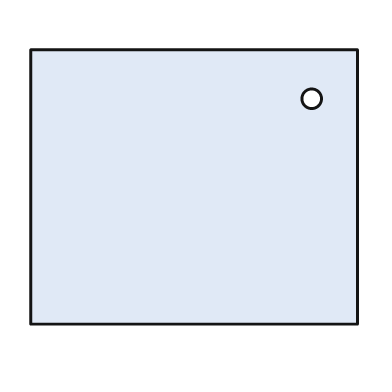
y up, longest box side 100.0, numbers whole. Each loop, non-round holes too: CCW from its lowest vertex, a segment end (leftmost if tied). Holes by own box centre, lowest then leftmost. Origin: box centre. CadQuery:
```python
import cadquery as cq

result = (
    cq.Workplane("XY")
    .moveTo(-50.0, -42.0)
    .lineTo(50.0, -42.0)
    .lineTo(50.0, 42.0)
    .lineTo(-50.0, 42.0)
    .close()
    .moveTo(36.0, 27.0)
    .circle(3.0)
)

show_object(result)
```